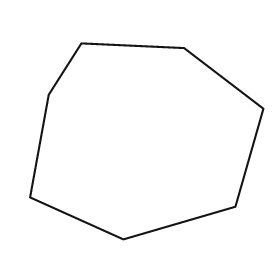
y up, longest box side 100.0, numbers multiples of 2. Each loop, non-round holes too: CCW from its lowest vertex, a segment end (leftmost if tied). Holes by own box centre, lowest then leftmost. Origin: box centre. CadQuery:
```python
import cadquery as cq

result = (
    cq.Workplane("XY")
    .moveTo(-10.0, -42.0)
    .lineTo(38.0, -28.0)
    .lineTo(50.0, 14.0)
    .lineTo(16.0, 40.0)
    .lineTo(-28.0, 42.0)
    .lineTo(-42.0, 20.0)
    .lineTo(-50.0, -24.0)
    .close()
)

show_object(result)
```